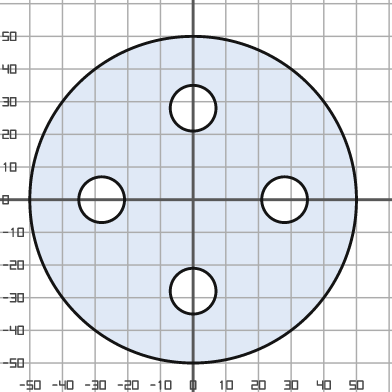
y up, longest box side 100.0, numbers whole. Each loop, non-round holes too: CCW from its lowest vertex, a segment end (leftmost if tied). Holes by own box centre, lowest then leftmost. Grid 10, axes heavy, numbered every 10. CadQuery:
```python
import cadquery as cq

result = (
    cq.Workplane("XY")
    .moveTo(0.0, 0.0)
    .circle(50.0)
    .moveTo(0.0, -28.0)
    .circle(7.0)
    .moveTo(-28.0, 0.0)
    .circle(7.0)
    .moveTo(28.0, 0.0)
    .circle(7.0)
    .moveTo(0.0, 28.0)
    .circle(7.0)
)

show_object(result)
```